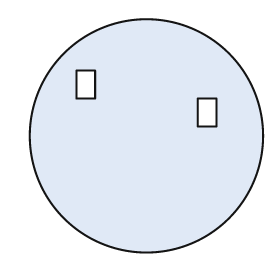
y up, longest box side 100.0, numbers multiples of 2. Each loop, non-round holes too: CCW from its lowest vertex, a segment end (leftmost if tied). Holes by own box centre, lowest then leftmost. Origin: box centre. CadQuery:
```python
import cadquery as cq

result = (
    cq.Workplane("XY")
    .moveTo(0.0, 0.0)
    .circle(50.0)
    .moveTo(22.0, 4.0)
    .lineTo(30.0, 4.0)
    .lineTo(30.0, 16.0)
    .lineTo(22.0, 16.0)
    .close()
    .moveTo(-30.0, 16.0)
    .lineTo(-22.0, 16.0)
    .lineTo(-22.0, 28.0)
    .lineTo(-30.0, 28.0)
    .close()
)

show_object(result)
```